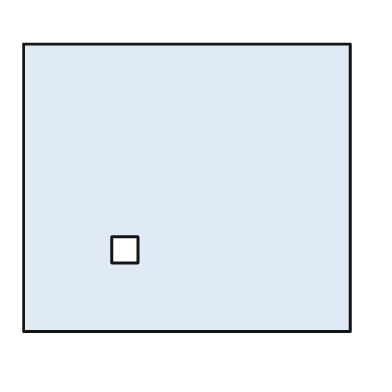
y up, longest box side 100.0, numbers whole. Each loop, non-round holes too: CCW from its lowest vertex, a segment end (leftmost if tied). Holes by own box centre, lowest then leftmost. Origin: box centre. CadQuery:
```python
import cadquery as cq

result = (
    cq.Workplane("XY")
    .moveTo(-50.0, -44.0)
    .lineTo(50.0, -44.0)
    .lineTo(50.0, 44.0)
    .lineTo(-50.0, 44.0)
    .close()
    .moveTo(-23.0, -23.0)
    .lineTo(-15.0, -23.0)
    .lineTo(-15.0, -15.0)
    .lineTo(-23.0, -15.0)
    .close()
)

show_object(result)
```